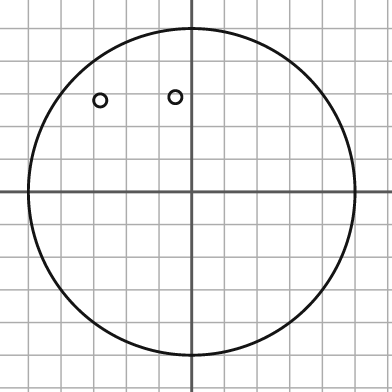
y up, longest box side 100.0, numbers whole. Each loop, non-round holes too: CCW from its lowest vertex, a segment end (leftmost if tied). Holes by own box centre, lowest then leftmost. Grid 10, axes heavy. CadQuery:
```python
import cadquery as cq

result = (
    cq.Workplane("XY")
    .moveTo(0.0, 0.0)
    .circle(50.0)
    .moveTo(-28.0, 28.0)
    .circle(2.0)
    .moveTo(-5.0, 29.0)
    .circle(2.0)
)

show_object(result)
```